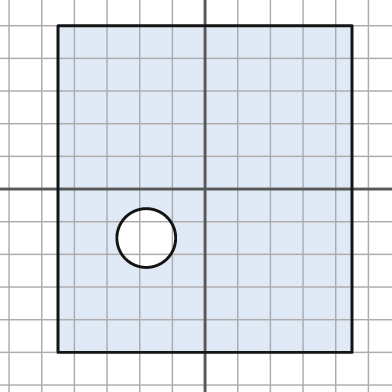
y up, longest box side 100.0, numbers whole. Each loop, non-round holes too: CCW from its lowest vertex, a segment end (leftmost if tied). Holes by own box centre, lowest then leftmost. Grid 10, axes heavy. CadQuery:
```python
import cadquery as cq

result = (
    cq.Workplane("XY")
    .moveTo(-45.0, -50.0)
    .lineTo(45.0, -50.0)
    .lineTo(45.0, 50.0)
    .lineTo(-45.0, 50.0)
    .close()
    .moveTo(-18.0, -15.0)
    .circle(9.0)
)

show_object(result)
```